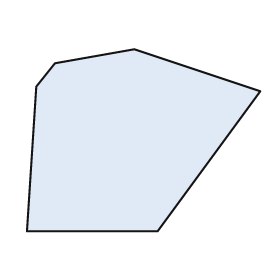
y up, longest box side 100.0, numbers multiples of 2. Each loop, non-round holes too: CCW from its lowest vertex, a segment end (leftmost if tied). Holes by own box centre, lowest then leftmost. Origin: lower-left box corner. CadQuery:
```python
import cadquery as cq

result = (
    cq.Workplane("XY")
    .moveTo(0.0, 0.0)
    .lineTo(56.0, 0.0)
    .lineTo(100.0, 60.0)
    .lineTo(46.0, 78.0)
    .lineTo(12.0, 72.0)
    .lineTo(4.0, 62.0)
    .close()
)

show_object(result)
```